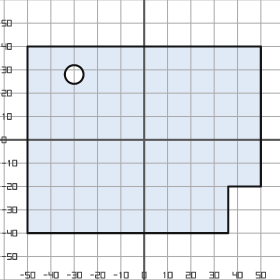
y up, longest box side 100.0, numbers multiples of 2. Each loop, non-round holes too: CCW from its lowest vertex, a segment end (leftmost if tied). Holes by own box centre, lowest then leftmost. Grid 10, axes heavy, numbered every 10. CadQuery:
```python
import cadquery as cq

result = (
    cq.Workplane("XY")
    .moveTo(-50.0, -40.0)
    .lineTo(36.0, -40.0)
    .lineTo(36.0, -20.0)
    .lineTo(50.0, -20.0)
    .lineTo(50.0, 40.0)
    .lineTo(-50.0, 40.0)
    .close()
    .moveTo(-30.0, 28.0)
    .circle(4.0)
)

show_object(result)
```